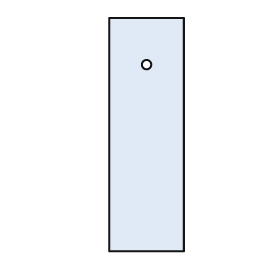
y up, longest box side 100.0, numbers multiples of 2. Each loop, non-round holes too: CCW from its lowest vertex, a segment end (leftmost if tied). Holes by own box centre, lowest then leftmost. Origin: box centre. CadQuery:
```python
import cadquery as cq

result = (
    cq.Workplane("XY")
    .moveTo(-16.0, -50.0)
    .lineTo(16.0, -50.0)
    .lineTo(16.0, 50.0)
    .lineTo(-16.0, 50.0)
    .close()
    .moveTo(0.0, 30.0)
    .circle(2.0)
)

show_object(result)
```